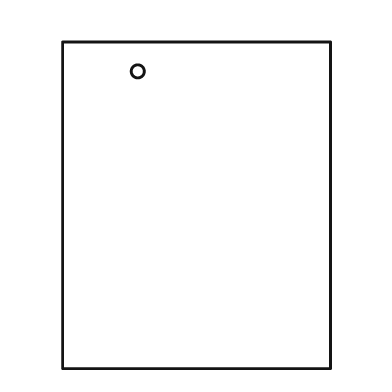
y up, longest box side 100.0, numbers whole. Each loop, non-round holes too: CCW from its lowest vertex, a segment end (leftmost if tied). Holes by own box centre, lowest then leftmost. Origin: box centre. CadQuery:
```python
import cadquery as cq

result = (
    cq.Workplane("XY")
    .moveTo(-41.0, -50.0)
    .lineTo(41.0, -50.0)
    .lineTo(41.0, 50.0)
    .lineTo(-41.0, 50.0)
    .close()
    .moveTo(-18.0, 41.0)
    .circle(2.0)
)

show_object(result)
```